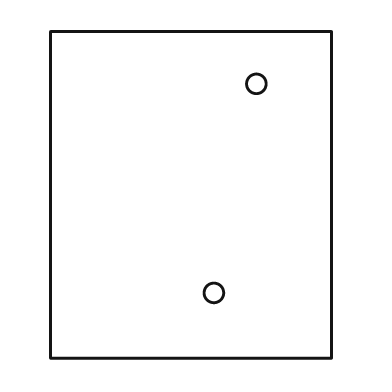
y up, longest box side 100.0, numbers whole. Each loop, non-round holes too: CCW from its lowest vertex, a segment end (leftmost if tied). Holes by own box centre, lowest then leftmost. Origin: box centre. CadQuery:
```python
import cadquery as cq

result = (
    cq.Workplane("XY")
    .moveTo(-43.0, -50.0)
    .lineTo(43.0, -50.0)
    .lineTo(43.0, 50.0)
    .lineTo(-43.0, 50.0)
    .close()
    .moveTo(7.0, -30.0)
    .circle(3.0)
    .moveTo(20.0, 34.0)
    .circle(3.0)
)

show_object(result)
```